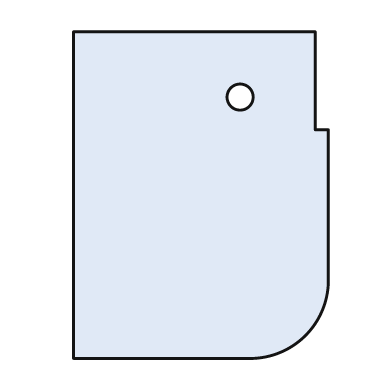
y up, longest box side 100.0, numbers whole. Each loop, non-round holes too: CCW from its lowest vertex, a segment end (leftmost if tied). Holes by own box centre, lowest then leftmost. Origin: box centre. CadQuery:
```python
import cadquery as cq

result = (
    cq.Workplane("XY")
    .moveTo(-39.0, -50.0)
    .lineTo(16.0, -50.0)
    .threePointArc((32.0, -43.0), (39.0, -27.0))
    .lineTo(39.0, 20.0)
    .lineTo(35.0, 20.0)
    .lineTo(35.0, 50.0)
    .lineTo(-39.0, 50.0)
    .close()
    .moveTo(12.0, 30.0)
    .circle(4.0)
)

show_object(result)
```